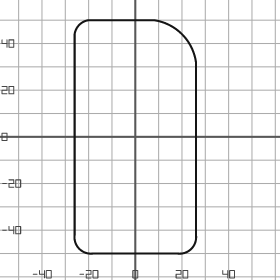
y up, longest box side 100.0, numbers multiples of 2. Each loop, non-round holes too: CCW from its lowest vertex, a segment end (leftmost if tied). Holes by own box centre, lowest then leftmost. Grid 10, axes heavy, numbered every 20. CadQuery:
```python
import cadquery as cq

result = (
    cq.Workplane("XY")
    .moveTo(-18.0, -50.0)
    .lineTo(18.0, -50.0)
    .threePointArc((24.0, -48.0), (26.0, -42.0))
    .lineTo(26.0, 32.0)
    .threePointArc((20.0, 44.0), (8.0, 50.0))
    .lineTo(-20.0, 50.0)
    .threePointArc((-24.0, 48.0), (-26.0, 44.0))
    .lineTo(-26.0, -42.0)
    .threePointArc((-24.0, -48.0), (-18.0, -50.0))
    .close()
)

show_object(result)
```